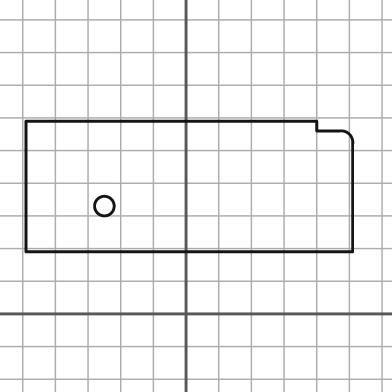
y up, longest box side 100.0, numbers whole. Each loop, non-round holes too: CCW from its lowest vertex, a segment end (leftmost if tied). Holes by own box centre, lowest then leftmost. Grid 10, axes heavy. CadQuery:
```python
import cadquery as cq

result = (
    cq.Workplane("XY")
    .moveTo(-49.0, 19.0)
    .lineTo(51.0, 19.0)
    .lineTo(51.0, 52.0)
    .threePointArc((50.0, 55.0), (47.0, 56.0))
    .lineTo(40.0, 56.0)
    .lineTo(40.0, 59.0)
    .lineTo(-49.0, 59.0)
    .close()
    .moveTo(-25.0, 33.0)
    .circle(3.0)
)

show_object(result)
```